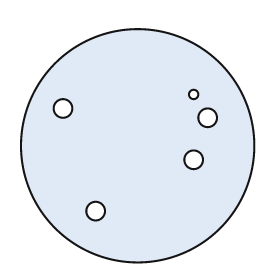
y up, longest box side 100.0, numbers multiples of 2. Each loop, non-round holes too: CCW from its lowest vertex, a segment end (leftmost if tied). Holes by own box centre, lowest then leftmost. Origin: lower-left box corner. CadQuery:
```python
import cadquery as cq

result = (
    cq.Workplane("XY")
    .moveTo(50.0, 50.0)
    .circle(50.0)
    .moveTo(32.0, 22.0)
    .circle(4.0)
    .moveTo(74.0, 44.0)
    .circle(4.0)
    .moveTo(80.0, 62.0)
    .circle(4.0)
    .moveTo(18.0, 66.0)
    .circle(4.0)
    .moveTo(74.0, 72.0)
    .circle(2.0)
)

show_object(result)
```